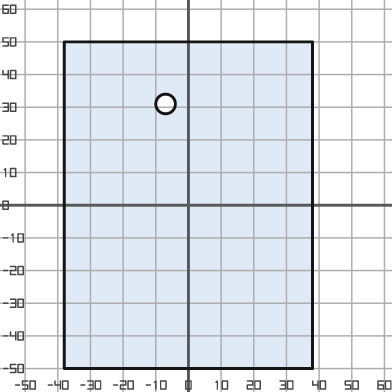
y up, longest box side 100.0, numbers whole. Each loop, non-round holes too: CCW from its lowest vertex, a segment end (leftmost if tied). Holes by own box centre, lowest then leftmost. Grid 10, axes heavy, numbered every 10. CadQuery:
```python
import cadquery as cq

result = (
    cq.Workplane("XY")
    .moveTo(-38.0, -50.0)
    .lineTo(38.0, -50.0)
    .lineTo(38.0, 50.0)
    .lineTo(-38.0, 50.0)
    .close()
    .moveTo(-7.0, 31.0)
    .circle(3.0)
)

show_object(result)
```